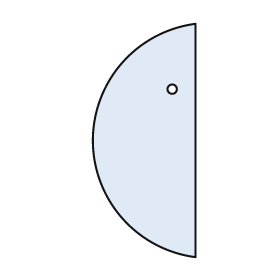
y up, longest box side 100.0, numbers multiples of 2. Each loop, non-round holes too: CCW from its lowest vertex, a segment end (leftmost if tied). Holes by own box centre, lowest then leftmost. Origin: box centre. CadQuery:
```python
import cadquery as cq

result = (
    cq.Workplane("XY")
    .moveTo(22.0, -50.0)
    .lineTo(22.0, 50.0)
    .threePointArc((-22.0, 0.0), (22.0, -50.0))
    .close()
    .moveTo(12.0, 22.0)
    .circle(2.0)
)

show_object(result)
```